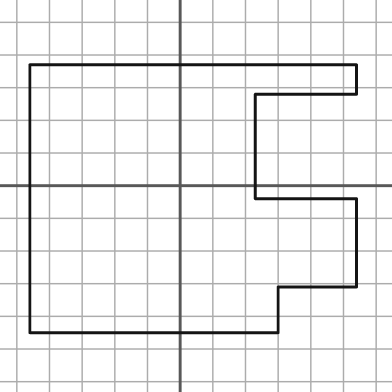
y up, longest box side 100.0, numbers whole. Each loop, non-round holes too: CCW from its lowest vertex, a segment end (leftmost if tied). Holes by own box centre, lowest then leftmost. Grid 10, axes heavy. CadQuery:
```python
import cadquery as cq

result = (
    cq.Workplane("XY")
    .moveTo(-46.0, -45.0)
    .lineTo(30.0, -45.0)
    .lineTo(30.0, -31.0)
    .lineTo(54.0, -31.0)
    .lineTo(54.0, -4.0)
    .lineTo(23.0, -4.0)
    .lineTo(23.0, 28.0)
    .lineTo(54.0, 28.0)
    .lineTo(54.0, 37.0)
    .lineTo(-46.0, 37.0)
    .close()
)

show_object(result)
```